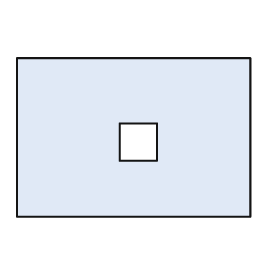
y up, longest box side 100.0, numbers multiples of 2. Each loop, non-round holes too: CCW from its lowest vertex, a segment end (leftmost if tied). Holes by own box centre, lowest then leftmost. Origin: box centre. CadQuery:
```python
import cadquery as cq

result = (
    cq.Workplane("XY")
    .moveTo(-50.0, -34.0)
    .lineTo(50.0, -34.0)
    .lineTo(50.0, 34.0)
    .lineTo(-50.0, 34.0)
    .close()
    .moveTo(-6.0, -10.0)
    .lineTo(10.0, -10.0)
    .lineTo(10.0, 6.0)
    .lineTo(-6.0, 6.0)
    .close()
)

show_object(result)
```